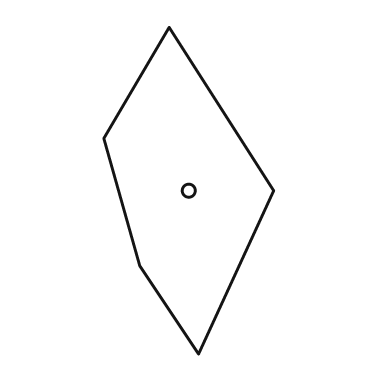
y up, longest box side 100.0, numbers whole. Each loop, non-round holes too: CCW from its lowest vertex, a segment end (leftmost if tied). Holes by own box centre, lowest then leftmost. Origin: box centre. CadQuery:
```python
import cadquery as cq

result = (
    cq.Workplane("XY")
    .moveTo(3.0, -50.0)
    .lineTo(26.0, 0.0)
    .lineTo(-6.0, 50.0)
    .lineTo(-26.0, 16.0)
    .lineTo(-15.0, -23.0)
    .close()
    .moveTo(0.0, 0.0)
    .circle(2.0)
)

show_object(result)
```